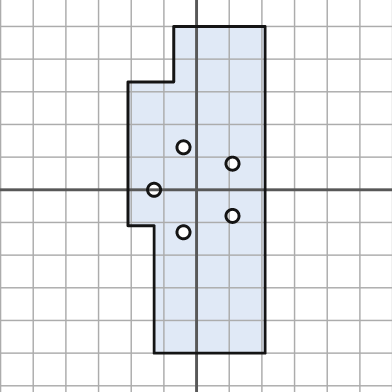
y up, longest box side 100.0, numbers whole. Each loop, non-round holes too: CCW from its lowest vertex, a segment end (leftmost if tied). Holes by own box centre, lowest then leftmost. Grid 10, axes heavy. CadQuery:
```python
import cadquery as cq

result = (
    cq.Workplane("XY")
    .moveTo(-13.0, -50.0)
    .lineTo(21.0, -50.0)
    .lineTo(21.0, 50.0)
    .lineTo(-7.0, 50.0)
    .lineTo(-7.0, 33.0)
    .lineTo(-21.0, 33.0)
    .lineTo(-21.0, -11.0)
    .lineTo(-13.0, -11.0)
    .close()
    .moveTo(-4.0, -13.0)
    .circle(2.0)
    .moveTo(11.0, -8.0)
    .circle(2.0)
    .moveTo(-13.0, 0.0)
    .circle(2.0)
    .moveTo(11.0, 8.0)
    .circle(2.0)
    .moveTo(-4.0, 13.0)
    .circle(2.0)
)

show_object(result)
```